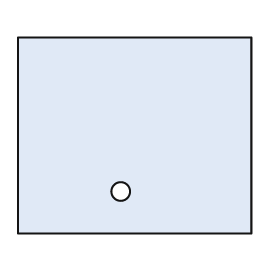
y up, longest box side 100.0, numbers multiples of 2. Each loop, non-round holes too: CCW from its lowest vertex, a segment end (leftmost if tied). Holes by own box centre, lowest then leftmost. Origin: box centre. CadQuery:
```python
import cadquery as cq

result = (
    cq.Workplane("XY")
    .moveTo(-50.0, -42.0)
    .lineTo(50.0, -42.0)
    .lineTo(50.0, 42.0)
    .lineTo(-50.0, 42.0)
    .close()
    .moveTo(-6.0, -24.0)
    .circle(4.0)
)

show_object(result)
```